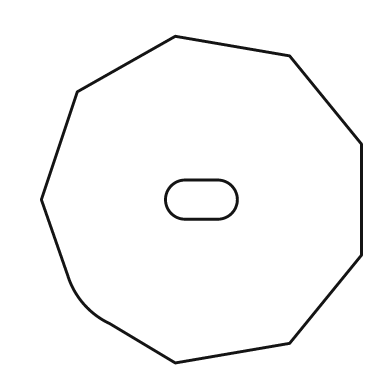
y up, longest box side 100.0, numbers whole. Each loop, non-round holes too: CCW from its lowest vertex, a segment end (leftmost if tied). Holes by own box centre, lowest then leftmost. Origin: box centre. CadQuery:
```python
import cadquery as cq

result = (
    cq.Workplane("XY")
    .moveTo(-8.0, -50.0)
    .lineTo(27.0, -44.0)
    .lineTo(49.0, -17.0)
    .lineTo(49.0, 17.0)
    .lineTo(27.0, 44.0)
    .lineTo(-8.0, 50.0)
    .lineTo(-38.0, 33.0)
    .lineTo(-49.0, 0.0)
    .lineTo(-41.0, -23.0)
    .threePointArc((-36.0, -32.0), (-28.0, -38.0))
    .close()
    .moveTo(-5.0, -6.0)
    .lineTo(5.0, -6.0)
    .threePointArc((11.0, 0.0), (5.0, 6.0))
    .lineTo(-5.0, 6.0)
    .threePointArc((-11.0, 0.0), (-5.0, -6.0))
    .close()
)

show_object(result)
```